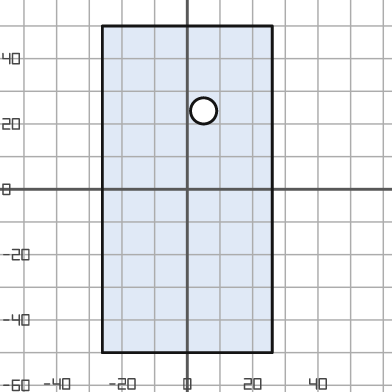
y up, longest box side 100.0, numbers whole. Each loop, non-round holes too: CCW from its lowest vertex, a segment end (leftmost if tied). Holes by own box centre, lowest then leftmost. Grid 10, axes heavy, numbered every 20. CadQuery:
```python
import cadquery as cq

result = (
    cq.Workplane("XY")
    .moveTo(-26.0, -50.0)
    .lineTo(26.0, -50.0)
    .lineTo(26.0, 50.0)
    .lineTo(-26.0, 50.0)
    .close()
    .moveTo(5.0, 24.0)
    .circle(4.0)
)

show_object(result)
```